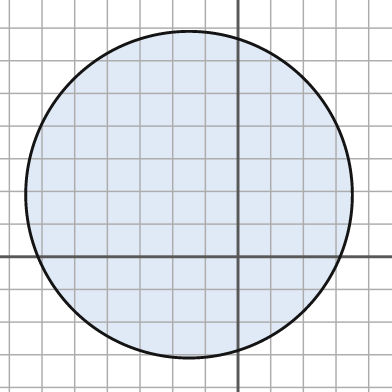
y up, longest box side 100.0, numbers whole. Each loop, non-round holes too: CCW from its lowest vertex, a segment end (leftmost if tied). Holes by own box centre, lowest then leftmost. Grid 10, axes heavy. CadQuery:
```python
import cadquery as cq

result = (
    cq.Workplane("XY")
    .moveTo(-15.0, 19.0)
    .circle(50.0)
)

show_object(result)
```